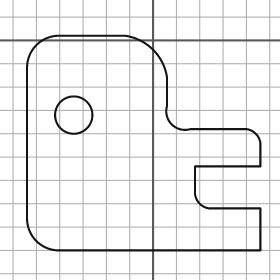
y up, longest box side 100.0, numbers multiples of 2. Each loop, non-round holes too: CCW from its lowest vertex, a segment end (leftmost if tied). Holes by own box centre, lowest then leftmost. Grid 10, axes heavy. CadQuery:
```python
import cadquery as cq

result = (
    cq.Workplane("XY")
    .moveTo(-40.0, -90.0)
    .lineTo(46.0, -90.0)
    .lineTo(46.0, -72.0)
    .lineTo(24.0, -72.0)
    .threePointArc((20.0, -70.0), (18.0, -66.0))
    .lineTo(18.0, -54.0)
    .lineTo(46.0, -54.0)
    .lineTo(46.0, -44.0)
    .threePointArc((44.0, -40.0), (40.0, -38.0))
    .lineTo(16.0, -38.0)
    .threePointArc((8.0, -36.0), (6.0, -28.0))
    .lineTo(6.0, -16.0)
    .threePointArc((0.0, -4.0), (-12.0, 2.0))
    .lineTo(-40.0, 2.0)
    .threePointArc((-50.0, -2.0), (-54.0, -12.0))
    .lineTo(-54.0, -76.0)
    .threePointArc((-50.0, -86.0), (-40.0, -90.0))
    .close()
    .moveTo(-34.0, -32.0)
    .circle(8.0)
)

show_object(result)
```